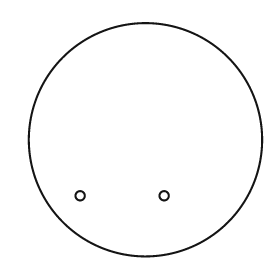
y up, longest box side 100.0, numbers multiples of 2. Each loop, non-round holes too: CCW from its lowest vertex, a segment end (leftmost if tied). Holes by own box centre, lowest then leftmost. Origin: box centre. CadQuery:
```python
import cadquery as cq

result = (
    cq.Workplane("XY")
    .moveTo(0.0, 0.0)
    .circle(50.0)
    .moveTo(-28.0, -24.0)
    .circle(2.0)
    .moveTo(8.0, -24.0)
    .circle(2.0)
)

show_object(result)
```